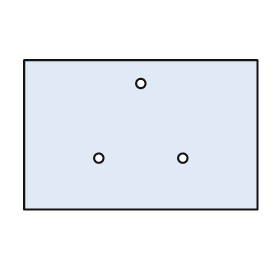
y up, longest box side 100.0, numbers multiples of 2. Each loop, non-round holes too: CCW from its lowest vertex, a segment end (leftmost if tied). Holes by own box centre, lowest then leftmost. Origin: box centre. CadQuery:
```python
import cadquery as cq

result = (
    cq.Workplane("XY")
    .moveTo(-50.0, -32.0)
    .lineTo(50.0, -32.0)
    .lineTo(50.0, 32.0)
    .lineTo(-50.0, 32.0)
    .close()
    .moveTo(-18.0, -10.0)
    .circle(2.0)
    .moveTo(18.0, -10.0)
    .circle(2.0)
    .moveTo(0.0, 22.0)
    .circle(2.0)
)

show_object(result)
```